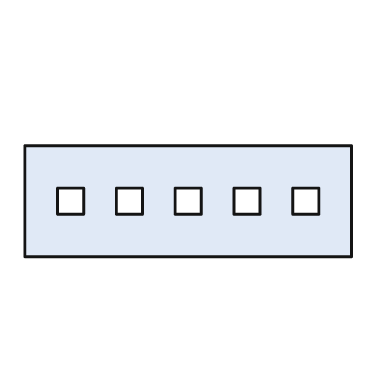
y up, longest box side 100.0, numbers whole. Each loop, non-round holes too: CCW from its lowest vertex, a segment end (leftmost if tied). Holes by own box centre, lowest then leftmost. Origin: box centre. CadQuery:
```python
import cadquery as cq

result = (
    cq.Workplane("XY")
    .moveTo(-50.0, -17.0)
    .lineTo(50.0, -17.0)
    .lineTo(50.0, 17.0)
    .lineTo(-50.0, 17.0)
    .close()
    .moveTo(-40.0, -4.0)
    .lineTo(-32.0, -4.0)
    .lineTo(-32.0, 4.0)
    .lineTo(-40.0, 4.0)
    .close()
    .moveTo(-22.0, -4.0)
    .lineTo(-14.0, -4.0)
    .lineTo(-14.0, 4.0)
    .lineTo(-22.0, 4.0)
    .close()
    .moveTo(-4.0, -4.0)
    .lineTo(4.0, -4.0)
    .lineTo(4.0, 4.0)
    .lineTo(-4.0, 4.0)
    .close()
    .moveTo(14.0, -4.0)
    .lineTo(22.0, -4.0)
    .lineTo(22.0, 4.0)
    .lineTo(14.0, 4.0)
    .close()
    .moveTo(32.0, -4.0)
    .lineTo(40.0, -4.0)
    .lineTo(40.0, 4.0)
    .lineTo(32.0, 4.0)
    .close()
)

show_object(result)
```